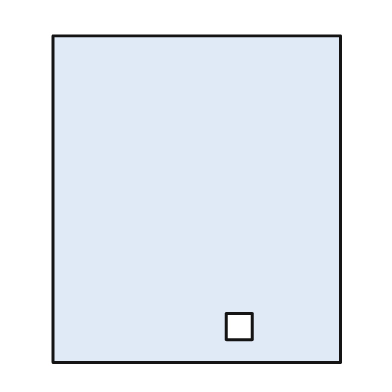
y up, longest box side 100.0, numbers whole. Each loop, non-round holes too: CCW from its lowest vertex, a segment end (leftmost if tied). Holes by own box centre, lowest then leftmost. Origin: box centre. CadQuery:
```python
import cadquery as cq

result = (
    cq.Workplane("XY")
    .moveTo(-44.0, -50.0)
    .lineTo(44.0, -50.0)
    .lineTo(44.0, 50.0)
    .lineTo(-44.0, 50.0)
    .close()
    .moveTo(9.0, -43.0)
    .lineTo(17.0, -43.0)
    .lineTo(17.0, -35.0)
    .lineTo(9.0, -35.0)
    .close()
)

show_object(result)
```